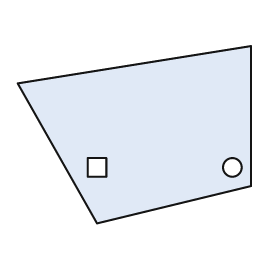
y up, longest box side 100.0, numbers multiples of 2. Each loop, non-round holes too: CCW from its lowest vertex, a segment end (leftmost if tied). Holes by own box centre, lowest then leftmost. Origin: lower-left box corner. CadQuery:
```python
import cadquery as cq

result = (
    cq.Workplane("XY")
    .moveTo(34.0, 0.0)
    .lineTo(100.0, 16.0)
    .lineTo(100.0, 76.0)
    .lineTo(0.0, 60.0)
    .close()
    .moveTo(30.0, 20.0)
    .lineTo(38.0, 20.0)
    .lineTo(38.0, 28.0)
    .lineTo(30.0, 28.0)
    .close()
    .moveTo(92.0, 24.0)
    .circle(4.0)
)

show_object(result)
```